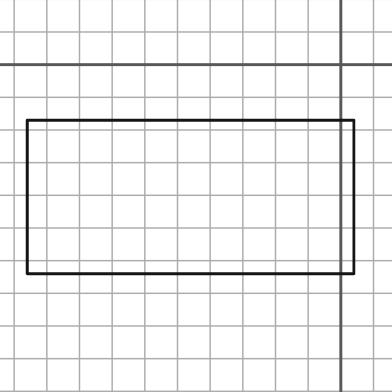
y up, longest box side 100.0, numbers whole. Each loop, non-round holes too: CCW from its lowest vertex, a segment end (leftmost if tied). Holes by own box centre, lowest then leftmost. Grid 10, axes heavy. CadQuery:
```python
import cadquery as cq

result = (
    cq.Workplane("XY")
    .moveTo(-96.0, -64.0)
    .lineTo(4.0, -64.0)
    .lineTo(4.0, -17.0)
    .lineTo(-96.0, -17.0)
    .close()
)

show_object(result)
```